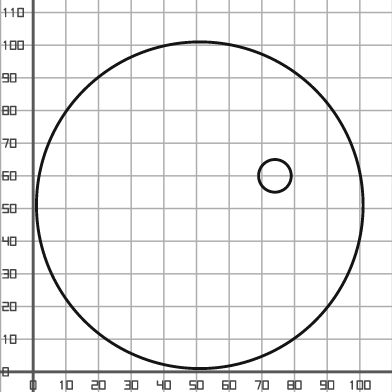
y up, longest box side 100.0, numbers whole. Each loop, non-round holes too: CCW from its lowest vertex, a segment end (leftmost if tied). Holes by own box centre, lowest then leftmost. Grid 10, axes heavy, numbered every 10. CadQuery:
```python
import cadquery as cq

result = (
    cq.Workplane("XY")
    .moveTo(51.0, 51.0)
    .circle(50.0)
    .moveTo(74.0, 60.0)
    .circle(5.0)
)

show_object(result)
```